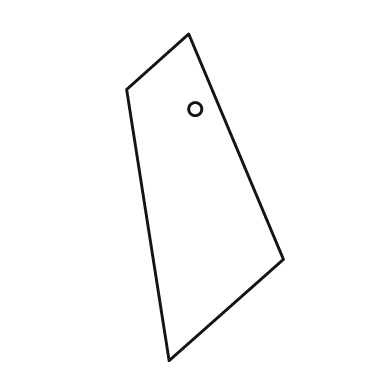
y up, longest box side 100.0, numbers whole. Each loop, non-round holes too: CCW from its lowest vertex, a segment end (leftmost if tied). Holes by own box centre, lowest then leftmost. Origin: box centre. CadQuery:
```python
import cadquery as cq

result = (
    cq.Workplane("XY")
    .moveTo(-11.0, -50.0)
    .lineTo(24.0, -19.0)
    .lineTo(-5.0, 50.0)
    .lineTo(-24.0, 33.0)
    .close()
    .moveTo(-3.0, 27.0)
    .circle(2.0)
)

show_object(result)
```